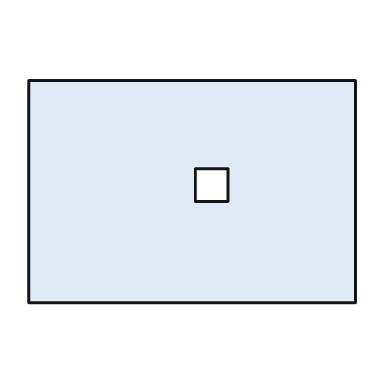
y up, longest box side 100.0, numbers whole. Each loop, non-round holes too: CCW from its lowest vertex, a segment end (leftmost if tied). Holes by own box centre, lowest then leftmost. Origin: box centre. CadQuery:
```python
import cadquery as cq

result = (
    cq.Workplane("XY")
    .moveTo(-50.0, -34.0)
    .lineTo(50.0, -34.0)
    .lineTo(50.0, 34.0)
    .lineTo(-50.0, 34.0)
    .close()
    .moveTo(1.0, -3.0)
    .lineTo(11.0, -3.0)
    .lineTo(11.0, 7.0)
    .lineTo(1.0, 7.0)
    .close()
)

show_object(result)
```